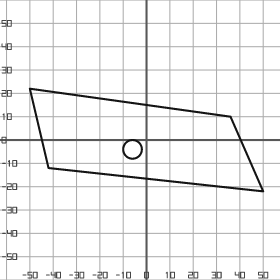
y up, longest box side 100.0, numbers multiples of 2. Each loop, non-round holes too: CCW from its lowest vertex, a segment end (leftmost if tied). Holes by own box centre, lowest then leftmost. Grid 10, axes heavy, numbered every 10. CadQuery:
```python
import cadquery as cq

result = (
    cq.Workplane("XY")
    .moveTo(50.0, -22.0)
    .lineTo(36.0, 10.0)
    .lineTo(-50.0, 22.0)
    .lineTo(-42.0, -12.0)
    .close()
    .moveTo(-6.0, -4.0)
    .circle(4.0)
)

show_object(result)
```